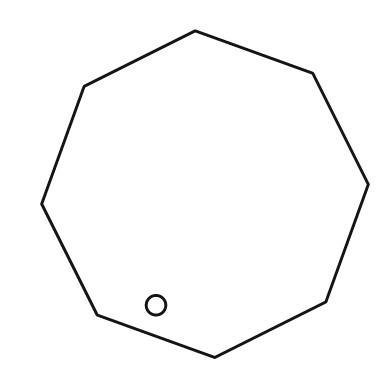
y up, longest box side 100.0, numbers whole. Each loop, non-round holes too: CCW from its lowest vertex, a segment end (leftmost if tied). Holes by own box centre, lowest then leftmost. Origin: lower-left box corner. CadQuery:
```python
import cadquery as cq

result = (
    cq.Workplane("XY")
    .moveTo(53.0, 0.0)
    .lineTo(87.0, 17.0)
    .lineTo(100.0, 53.0)
    .lineTo(83.0, 87.0)
    .lineTo(47.0, 100.0)
    .lineTo(13.0, 83.0)
    .lineTo(0.0, 47.0)
    .lineTo(17.0, 13.0)
    .close()
    .moveTo(35.0, 16.0)
    .circle(3.0)
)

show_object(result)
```